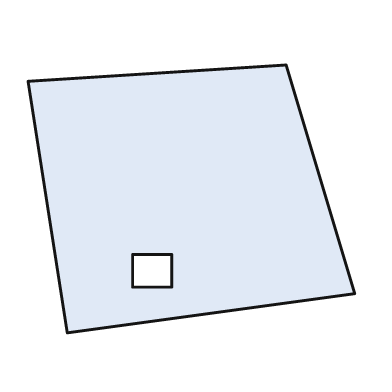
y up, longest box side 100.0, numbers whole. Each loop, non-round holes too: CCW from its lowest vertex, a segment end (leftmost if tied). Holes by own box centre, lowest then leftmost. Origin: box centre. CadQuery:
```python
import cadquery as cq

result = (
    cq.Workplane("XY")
    .moveTo(-38.0, -41.0)
    .lineTo(50.0, -29.0)
    .lineTo(29.0, 41.0)
    .lineTo(-50.0, 36.0)
    .close()
    .moveTo(-18.0, -27.0)
    .lineTo(-6.0, -27.0)
    .lineTo(-6.0, -17.0)
    .lineTo(-18.0, -17.0)
    .close()
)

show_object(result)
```